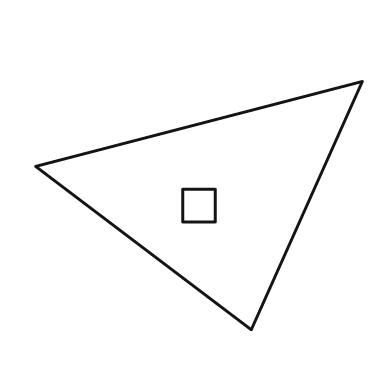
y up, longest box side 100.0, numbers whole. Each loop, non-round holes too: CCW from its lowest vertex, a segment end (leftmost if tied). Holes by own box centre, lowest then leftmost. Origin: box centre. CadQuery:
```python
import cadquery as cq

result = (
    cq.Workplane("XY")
    .moveTo(16.0, -38.0)
    .lineTo(50.0, 38.0)
    .lineTo(-50.0, 12.0)
    .close()
    .moveTo(-5.0, -5.0)
    .lineTo(5.0, -5.0)
    .lineTo(5.0, 5.0)
    .lineTo(-5.0, 5.0)
    .close()
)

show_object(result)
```